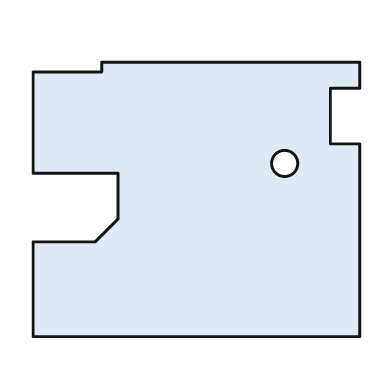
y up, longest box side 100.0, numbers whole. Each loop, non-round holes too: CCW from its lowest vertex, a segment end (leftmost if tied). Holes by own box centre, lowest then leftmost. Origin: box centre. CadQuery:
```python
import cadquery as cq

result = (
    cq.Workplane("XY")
    .moveTo(-50.0, -42.0)
    .lineTo(50.0, -42.0)
    .lineTo(50.0, 17.0)
    .lineTo(41.0, 17.0)
    .lineTo(41.0, 34.0)
    .lineTo(50.0, 34.0)
    .lineTo(50.0, 42.0)
    .lineTo(-29.0, 42.0)
    .lineTo(-29.0, 39.0)
    .lineTo(-50.0, 39.0)
    .lineTo(-50.0, 8.0)
    .lineTo(-24.0, 8.0)
    .lineTo(-24.0, -6.0)
    .lineTo(-31.0, -13.0)
    .lineTo(-50.0, -13.0)
    .close()
    .moveTo(27.0, 11.0)
    .circle(4.0)
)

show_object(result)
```